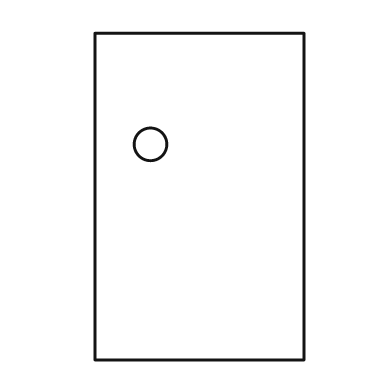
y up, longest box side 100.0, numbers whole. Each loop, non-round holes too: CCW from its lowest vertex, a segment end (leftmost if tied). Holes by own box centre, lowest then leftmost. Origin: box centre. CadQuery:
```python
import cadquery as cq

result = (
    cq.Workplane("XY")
    .moveTo(-32.0, -50.0)
    .lineTo(32.0, -50.0)
    .lineTo(32.0, 50.0)
    .lineTo(-32.0, 50.0)
    .close()
    .moveTo(-15.0, 16.0)
    .circle(5.0)
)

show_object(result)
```